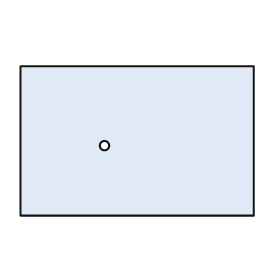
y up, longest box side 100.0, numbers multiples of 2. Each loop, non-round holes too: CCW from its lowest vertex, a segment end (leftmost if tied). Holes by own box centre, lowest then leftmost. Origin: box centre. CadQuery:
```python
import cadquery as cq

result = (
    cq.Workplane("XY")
    .moveTo(-50.0, -32.0)
    .lineTo(50.0, -32.0)
    .lineTo(50.0, 32.0)
    .lineTo(-50.0, 32.0)
    .close()
    .moveTo(-14.0, -2.0)
    .circle(2.0)
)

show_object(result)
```